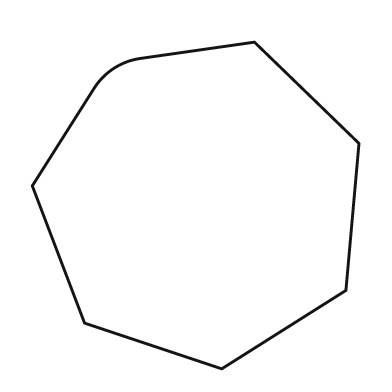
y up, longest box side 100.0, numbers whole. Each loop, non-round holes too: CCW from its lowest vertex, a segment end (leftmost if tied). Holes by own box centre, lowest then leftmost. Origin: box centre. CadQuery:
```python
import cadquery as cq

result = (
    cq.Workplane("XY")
    .moveTo(8.0, -50.0)
    .lineTo(46.0, -26.0)
    .lineTo(50.0, 19.0)
    .lineTo(18.0, 50.0)
    .lineTo(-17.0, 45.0)
    .threePointArc((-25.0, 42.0), (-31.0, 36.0))
    .lineTo(-50.0, 6.0)
    .lineTo(-34.0, -36.0)
    .close()
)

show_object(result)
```